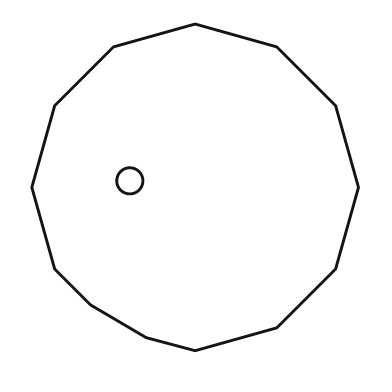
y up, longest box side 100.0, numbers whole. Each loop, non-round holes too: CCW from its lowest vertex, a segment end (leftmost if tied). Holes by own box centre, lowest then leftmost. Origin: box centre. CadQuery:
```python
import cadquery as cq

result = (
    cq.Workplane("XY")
    .moveTo(0.0, -50.0)
    .lineTo(25.0, -43.0)
    .lineTo(43.0, -25.0)
    .lineTo(50.0, 0.0)
    .lineTo(43.0, 25.0)
    .lineTo(25.0, 43.0)
    .lineTo(0.0, 50.0)
    .lineTo(-25.0, 43.0)
    .lineTo(-43.0, 25.0)
    .lineTo(-50.0, 0.0)
    .lineTo(-43.0, -25.0)
    .lineTo(-32.0, -36.0)
    .lineTo(-15.0, -46.0)
    .close()
    .moveTo(-20.0, 2.0)
    .circle(4.0)
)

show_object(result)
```